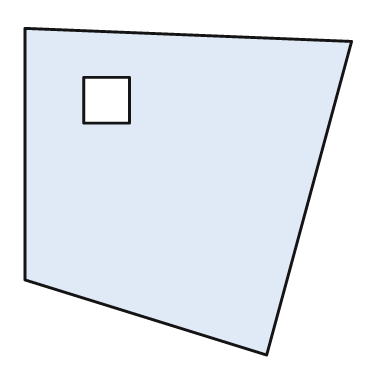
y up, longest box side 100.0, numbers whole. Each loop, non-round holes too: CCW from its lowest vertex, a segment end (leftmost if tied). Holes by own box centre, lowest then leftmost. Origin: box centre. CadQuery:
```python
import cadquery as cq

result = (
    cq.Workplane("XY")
    .moveTo(24.0, -50.0)
    .lineTo(50.0, 46.0)
    .lineTo(-50.0, 50.0)
    .lineTo(-50.0, -27.0)
    .close()
    .moveTo(-32.0, 21.0)
    .lineTo(-18.0, 21.0)
    .lineTo(-18.0, 35.0)
    .lineTo(-32.0, 35.0)
    .close()
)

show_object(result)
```